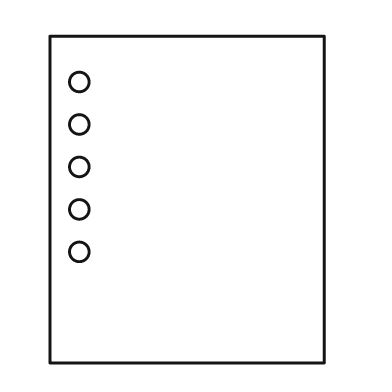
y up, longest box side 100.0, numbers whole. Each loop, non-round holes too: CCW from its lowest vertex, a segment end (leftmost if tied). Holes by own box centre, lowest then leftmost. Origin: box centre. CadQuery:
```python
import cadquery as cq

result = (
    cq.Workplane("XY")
    .moveTo(-42.0, -50.0)
    .lineTo(42.0, -50.0)
    .lineTo(42.0, 50.0)
    .lineTo(-42.0, 50.0)
    .close()
    .moveTo(-33.0, -16.0)
    .circle(3.0)
    .moveTo(-33.0, -3.0)
    .circle(3.0)
    .moveTo(-33.0, 10.0)
    .circle(3.0)
    .moveTo(-33.0, 23.0)
    .circle(3.0)
    .moveTo(-33.0, 36.0)
    .circle(3.0)
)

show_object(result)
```